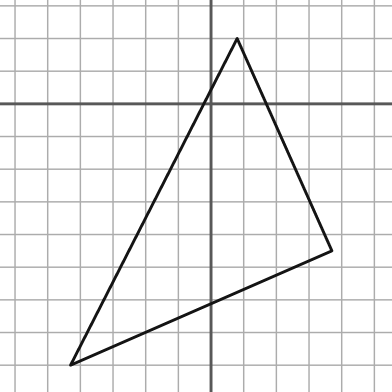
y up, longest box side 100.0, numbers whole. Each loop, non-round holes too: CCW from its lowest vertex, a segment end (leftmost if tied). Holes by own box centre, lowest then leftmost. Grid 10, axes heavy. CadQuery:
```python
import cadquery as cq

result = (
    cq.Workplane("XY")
    .moveTo(-43.0, -80.0)
    .lineTo(37.0, -45.0)
    .lineTo(8.0, 20.0)
    .close()
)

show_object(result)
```